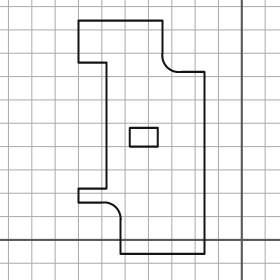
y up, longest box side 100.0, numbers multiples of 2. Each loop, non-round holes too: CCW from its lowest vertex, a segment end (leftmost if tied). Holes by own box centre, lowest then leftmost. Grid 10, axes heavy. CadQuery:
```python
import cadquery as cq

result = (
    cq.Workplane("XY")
    .moveTo(-52.0, -6.0)
    .lineTo(-16.0, -6.0)
    .lineTo(-16.0, 72.0)
    .lineTo(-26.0, 72.0)
    .threePointArc((-32.0, 74.0), (-34.0, 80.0))
    .lineTo(-34.0, 94.0)
    .lineTo(-70.0, 94.0)
    .lineTo(-70.0, 76.0)
    .lineTo(-58.0, 76.0)
    .lineTo(-58.0, 22.0)
    .lineTo(-70.0, 22.0)
    .lineTo(-70.0, 16.0)
    .lineTo(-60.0, 16.0)
    .threePointArc((-54.0, 14.0), (-52.0, 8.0))
    .close()
    .moveTo(-48.0, 40.0)
    .lineTo(-36.0, 40.0)
    .lineTo(-36.0, 48.0)
    .lineTo(-48.0, 48.0)
    .close()
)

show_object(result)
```